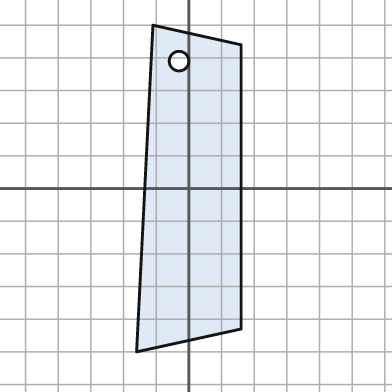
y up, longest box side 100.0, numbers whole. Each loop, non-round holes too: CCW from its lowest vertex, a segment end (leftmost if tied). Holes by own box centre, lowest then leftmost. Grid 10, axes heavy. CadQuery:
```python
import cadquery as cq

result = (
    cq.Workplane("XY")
    .moveTo(-16.0, -50.0)
    .lineTo(16.0, -43.0)
    .lineTo(16.0, 44.0)
    .lineTo(-11.0, 50.0)
    .close()
    .moveTo(-3.0, 39.0)
    .circle(3.0)
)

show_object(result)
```